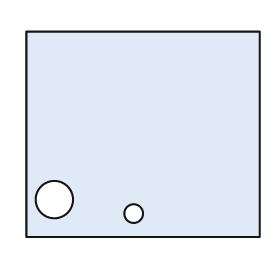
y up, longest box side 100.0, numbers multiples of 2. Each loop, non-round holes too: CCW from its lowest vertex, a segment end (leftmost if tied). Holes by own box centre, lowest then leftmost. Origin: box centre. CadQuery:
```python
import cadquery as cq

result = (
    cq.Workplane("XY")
    .moveTo(-50.0, -44.0)
    .lineTo(50.0, -44.0)
    .lineTo(50.0, 44.0)
    .lineTo(-50.0, 44.0)
    .close()
    .moveTo(-4.0, -34.0)
    .circle(4.0)
    .moveTo(-38.0, -28.0)
    .circle(8.0)
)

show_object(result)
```